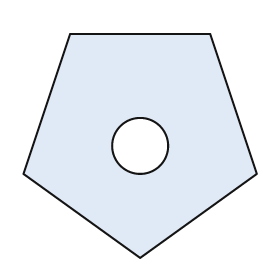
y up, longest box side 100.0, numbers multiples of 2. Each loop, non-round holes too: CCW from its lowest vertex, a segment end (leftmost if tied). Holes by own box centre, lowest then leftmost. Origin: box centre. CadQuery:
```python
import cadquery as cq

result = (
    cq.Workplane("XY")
    .moveTo(0.0, -48.0)
    .lineTo(50.0, -12.0)
    .lineTo(30.0, 48.0)
    .lineTo(-30.0, 48.0)
    .lineTo(-50.0, -12.0)
    .close()
    .moveTo(0.0, 0.0)
    .circle(12.0)
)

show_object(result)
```